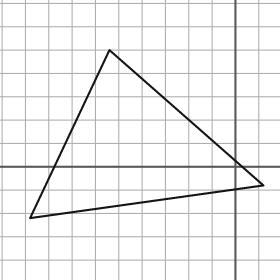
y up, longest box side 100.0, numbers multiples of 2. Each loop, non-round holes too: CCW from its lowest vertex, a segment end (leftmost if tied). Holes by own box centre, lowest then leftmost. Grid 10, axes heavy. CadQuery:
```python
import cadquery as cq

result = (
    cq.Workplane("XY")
    .moveTo(-88.0, -22.0)
    .lineTo(12.0, -8.0)
    .lineTo(-54.0, 50.0)
    .close()
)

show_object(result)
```